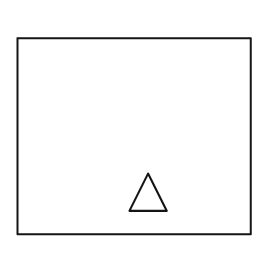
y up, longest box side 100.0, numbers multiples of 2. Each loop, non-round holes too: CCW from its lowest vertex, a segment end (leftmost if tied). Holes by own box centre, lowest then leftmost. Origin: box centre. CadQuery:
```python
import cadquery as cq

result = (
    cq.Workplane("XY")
    .moveTo(-50.0, -42.0)
    .lineTo(50.0, -42.0)
    .lineTo(50.0, 42.0)
    .lineTo(-50.0, 42.0)
    .close()
    .moveTo(-2.0, -32.0)
    .lineTo(14.0, -32.0)
    .lineTo(6.0, -16.0)
    .close()
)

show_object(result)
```